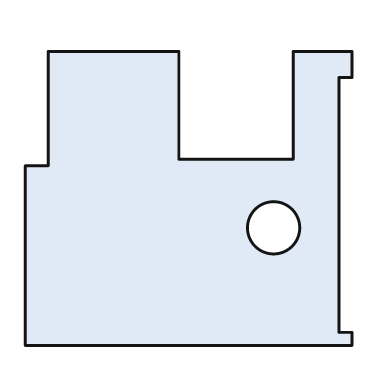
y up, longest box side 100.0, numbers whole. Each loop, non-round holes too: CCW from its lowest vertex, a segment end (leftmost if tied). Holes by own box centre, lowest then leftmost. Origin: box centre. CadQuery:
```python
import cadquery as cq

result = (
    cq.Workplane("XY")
    .moveTo(-50.0, -45.0)
    .lineTo(50.0, -45.0)
    .lineTo(50.0, -41.0)
    .lineTo(46.0, -41.0)
    .lineTo(46.0, 37.0)
    .lineTo(50.0, 37.0)
    .lineTo(50.0, 45.0)
    .lineTo(32.0, 45.0)
    .lineTo(32.0, 12.0)
    .lineTo(-3.0, 12.0)
    .lineTo(-3.0, 45.0)
    .lineTo(-43.0, 45.0)
    .lineTo(-43.0, 10.0)
    .lineTo(-50.0, 10.0)
    .close()
    .moveTo(26.0, -9.0)
    .circle(8.0)
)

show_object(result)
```